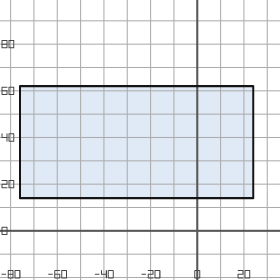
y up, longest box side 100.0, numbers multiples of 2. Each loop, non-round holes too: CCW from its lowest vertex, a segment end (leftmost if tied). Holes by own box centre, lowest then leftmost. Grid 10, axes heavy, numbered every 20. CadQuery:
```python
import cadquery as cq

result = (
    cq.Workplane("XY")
    .moveTo(-76.0, 14.0)
    .lineTo(24.0, 14.0)
    .lineTo(24.0, 62.0)
    .lineTo(-76.0, 62.0)
    .close()
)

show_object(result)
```